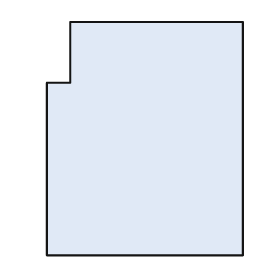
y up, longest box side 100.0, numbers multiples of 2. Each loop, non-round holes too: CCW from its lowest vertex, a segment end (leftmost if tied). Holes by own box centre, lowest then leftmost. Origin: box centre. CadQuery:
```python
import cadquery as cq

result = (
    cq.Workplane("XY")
    .moveTo(-42.0, -50.0)
    .lineTo(42.0, -50.0)
    .lineTo(42.0, 50.0)
    .lineTo(-32.0, 50.0)
    .lineTo(-32.0, 24.0)
    .lineTo(-42.0, 24.0)
    .close()
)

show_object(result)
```